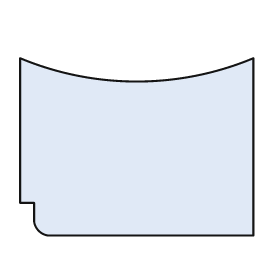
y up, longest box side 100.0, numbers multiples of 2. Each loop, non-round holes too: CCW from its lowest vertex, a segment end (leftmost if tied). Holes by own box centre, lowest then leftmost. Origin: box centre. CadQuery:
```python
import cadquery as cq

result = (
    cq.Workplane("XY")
    .moveTo(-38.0, -38.0)
    .lineTo(50.0, -38.0)
    .lineTo(50.0, 38.0)
    .threePointArc((0.0, 28.0), (-50.0, 38.0))
    .lineTo(-50.0, -24.0)
    .lineTo(-44.0, -24.0)
    .lineTo(-44.0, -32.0)
    .threePointArc((-42.0, -36.0), (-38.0, -38.0))
    .close()
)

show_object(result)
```